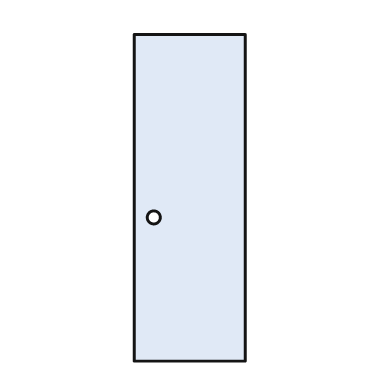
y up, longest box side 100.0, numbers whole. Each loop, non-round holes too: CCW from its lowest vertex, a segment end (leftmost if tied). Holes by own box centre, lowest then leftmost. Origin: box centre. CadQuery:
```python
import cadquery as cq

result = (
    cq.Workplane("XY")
    .moveTo(-17.0, -50.0)
    .lineTo(17.0, -50.0)
    .lineTo(17.0, 50.0)
    .lineTo(-17.0, 50.0)
    .close()
    .moveTo(-11.0, -6.0)
    .circle(2.0)
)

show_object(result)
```